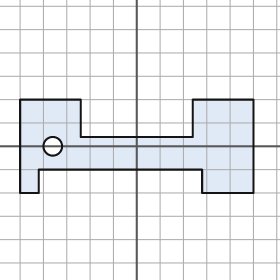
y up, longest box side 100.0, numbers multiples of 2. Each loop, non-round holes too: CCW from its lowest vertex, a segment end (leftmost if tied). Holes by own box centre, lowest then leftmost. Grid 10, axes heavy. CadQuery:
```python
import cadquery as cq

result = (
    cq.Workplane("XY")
    .moveTo(-50.0, -20.0)
    .lineTo(-42.0, -20.0)
    .lineTo(-42.0, -10.0)
    .lineTo(28.0, -10.0)
    .lineTo(28.0, -20.0)
    .lineTo(50.0, -20.0)
    .lineTo(50.0, 20.0)
    .lineTo(24.0, 20.0)
    .lineTo(24.0, 4.0)
    .lineTo(-24.0, 4.0)
    .lineTo(-24.0, 20.0)
    .lineTo(-50.0, 20.0)
    .close()
    .moveTo(-36.0, 0.0)
    .circle(4.0)
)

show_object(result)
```